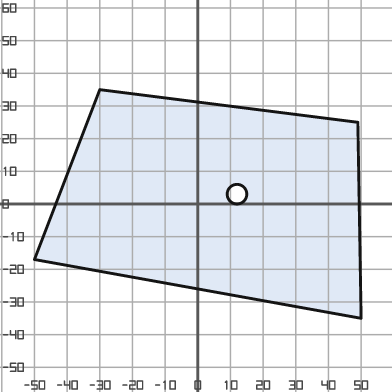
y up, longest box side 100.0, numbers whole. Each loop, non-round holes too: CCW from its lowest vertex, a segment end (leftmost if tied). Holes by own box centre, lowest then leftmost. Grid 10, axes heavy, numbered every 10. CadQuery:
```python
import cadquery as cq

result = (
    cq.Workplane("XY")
    .moveTo(50.0, -35.0)
    .lineTo(49.0, 25.0)
    .lineTo(-30.0, 35.0)
    .lineTo(-50.0, -17.0)
    .close()
    .moveTo(12.0, 3.0)
    .circle(3.0)
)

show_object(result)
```